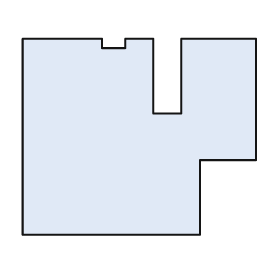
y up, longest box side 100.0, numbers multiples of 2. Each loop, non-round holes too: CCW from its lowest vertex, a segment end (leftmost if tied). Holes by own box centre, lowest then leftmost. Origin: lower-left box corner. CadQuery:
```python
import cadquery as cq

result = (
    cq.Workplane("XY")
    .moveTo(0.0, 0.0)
    .lineTo(76.0, 0.0)
    .lineTo(76.0, 32.0)
    .lineTo(100.0, 32.0)
    .lineTo(100.0, 84.0)
    .lineTo(68.0, 84.0)
    .lineTo(68.0, 52.0)
    .lineTo(56.0, 52.0)
    .lineTo(56.0, 84.0)
    .lineTo(44.0, 84.0)
    .lineTo(44.0, 80.0)
    .lineTo(34.0, 80.0)
    .lineTo(34.0, 84.0)
    .lineTo(0.0, 84.0)
    .close()
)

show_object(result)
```